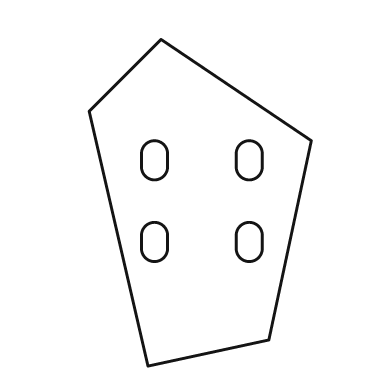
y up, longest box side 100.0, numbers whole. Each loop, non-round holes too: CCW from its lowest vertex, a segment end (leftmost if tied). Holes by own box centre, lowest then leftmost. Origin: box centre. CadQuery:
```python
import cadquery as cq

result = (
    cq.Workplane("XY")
    .moveTo(-16.0, -50.0)
    .lineTo(21.0, -42.0)
    .lineTo(34.0, 19.0)
    .lineTo(-12.0, 50.0)
    .lineTo(-34.0, 28.0)
    .close()
    .moveTo(-18.0, -14.0)
    .threePointArc((-14.0, -18.0), (-10.0, -14.0))
    .lineTo(-10.0, -10.0)
    .threePointArc((-14.0, -6.0), (-18.0, -10.0))
    .close()
    .moveTo(11.0, -14.0)
    .threePointArc((15.0, -18.0), (19.0, -14.0))
    .lineTo(19.0, -10.0)
    .threePointArc((15.0, -6.0), (11.0, -10.0))
    .close()
    .moveTo(-18.0, 11.0)
    .threePointArc((-14.0, 7.0), (-10.0, 11.0))
    .lineTo(-10.0, 15.0)
    .threePointArc((-14.0, 19.0), (-18.0, 15.0))
    .close()
    .moveTo(11.0, 11.0)
    .threePointArc((15.0, 7.0), (19.0, 11.0))
    .lineTo(19.0, 15.0)
    .threePointArc((15.0, 19.0), (11.0, 15.0))
    .close()
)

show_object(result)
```